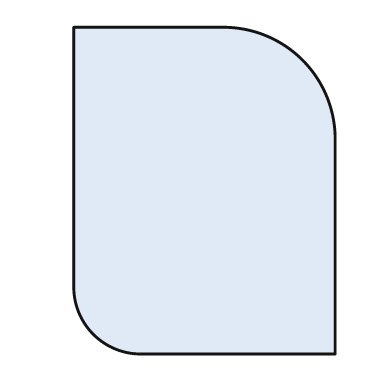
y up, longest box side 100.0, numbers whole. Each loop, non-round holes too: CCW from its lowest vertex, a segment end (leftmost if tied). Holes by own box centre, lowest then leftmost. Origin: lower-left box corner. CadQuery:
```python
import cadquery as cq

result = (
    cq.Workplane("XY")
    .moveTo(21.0, 0.0)
    .lineTo(80.0, 0.0)
    .lineTo(80.0, 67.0)
    .threePointArc((70.0, 90.0), (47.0, 100.0))
    .lineTo(0.0, 100.0)
    .lineTo(0.0, 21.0)
    .threePointArc((6.0, 6.0), (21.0, 0.0))
    .close()
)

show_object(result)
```